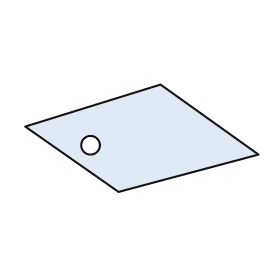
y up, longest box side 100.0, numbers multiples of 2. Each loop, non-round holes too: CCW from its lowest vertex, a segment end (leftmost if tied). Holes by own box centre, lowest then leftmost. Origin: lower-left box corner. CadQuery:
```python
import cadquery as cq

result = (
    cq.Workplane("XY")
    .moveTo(40.0, 0.0)
    .lineTo(100.0, 16.0)
    .lineTo(58.0, 46.0)
    .lineTo(0.0, 28.0)
    .close()
    .moveTo(28.0, 20.0)
    .circle(4.0)
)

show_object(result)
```